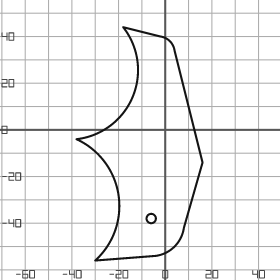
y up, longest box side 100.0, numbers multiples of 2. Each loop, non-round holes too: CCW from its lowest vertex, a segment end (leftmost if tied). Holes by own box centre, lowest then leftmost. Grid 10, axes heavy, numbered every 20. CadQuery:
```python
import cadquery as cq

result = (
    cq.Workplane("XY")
    .moveTo(-30.0, -56.0)
    .lineTo(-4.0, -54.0)
    .threePointArc((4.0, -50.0), (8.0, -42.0))
    .lineTo(16.0, -14.0)
    .lineTo(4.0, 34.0)
    .threePointArc((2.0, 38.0), (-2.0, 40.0))
    .lineTo(-18.0, 44.0)
    .threePointArc((-14.0, 14.0), (-38.0, -4.0))
    .threePointArc((-20.0, -28.0), (-30.0, -56.0))
    .close()
    .moveTo(-6.0, -38.0)
    .circle(2.0)
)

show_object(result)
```